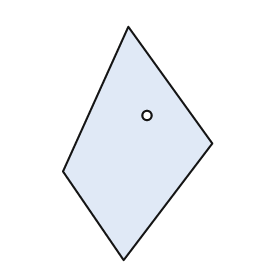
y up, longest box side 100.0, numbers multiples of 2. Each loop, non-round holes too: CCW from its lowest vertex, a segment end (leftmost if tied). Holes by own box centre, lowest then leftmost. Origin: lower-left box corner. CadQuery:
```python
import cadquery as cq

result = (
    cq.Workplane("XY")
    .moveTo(26.0, 0.0)
    .lineTo(64.0, 50.0)
    .lineTo(28.0, 100.0)
    .lineTo(0.0, 38.0)
    .close()
    .moveTo(36.0, 62.0)
    .circle(2.0)
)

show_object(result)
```